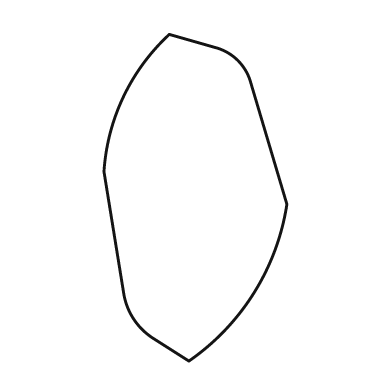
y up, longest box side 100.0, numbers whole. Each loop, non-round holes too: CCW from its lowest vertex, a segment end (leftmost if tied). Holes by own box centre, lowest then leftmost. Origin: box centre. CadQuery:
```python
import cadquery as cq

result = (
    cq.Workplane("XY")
    .moveTo(-2.0, -50.0)
    .threePointArc((18.0, -29.0), (28.0, -2.0))
    .lineTo(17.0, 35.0)
    .threePointArc((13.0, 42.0), (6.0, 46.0))
    .lineTo(-8.0, 50.0)
    .threePointArc((-22.0, 31.0), (-28.0, 8.0))
    .lineTo(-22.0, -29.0)
    .threePointArc((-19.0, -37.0), (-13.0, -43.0))
    .close()
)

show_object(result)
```